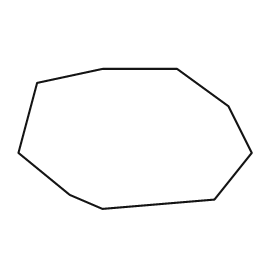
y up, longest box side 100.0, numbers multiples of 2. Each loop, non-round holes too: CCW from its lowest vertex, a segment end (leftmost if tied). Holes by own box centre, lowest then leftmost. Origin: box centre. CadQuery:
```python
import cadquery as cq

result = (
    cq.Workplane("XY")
    .moveTo(-14.0, -30.0)
    .lineTo(34.0, -26.0)
    .lineTo(50.0, -6.0)
    .lineTo(40.0, 14.0)
    .lineTo(18.0, 30.0)
    .lineTo(-14.0, 30.0)
    .lineTo(-42.0, 24.0)
    .lineTo(-50.0, -6.0)
    .lineTo(-28.0, -24.0)
    .close()
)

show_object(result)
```